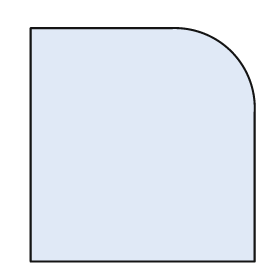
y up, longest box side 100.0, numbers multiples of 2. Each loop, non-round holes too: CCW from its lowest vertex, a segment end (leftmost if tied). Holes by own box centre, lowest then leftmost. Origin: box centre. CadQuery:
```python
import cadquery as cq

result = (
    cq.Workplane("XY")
    .moveTo(-48.0, -50.0)
    .lineTo(48.0, -50.0)
    .lineTo(48.0, 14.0)
    .threePointArc((38.0, 40.0), (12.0, 50.0))
    .lineTo(-48.0, 50.0)
    .close()
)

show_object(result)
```